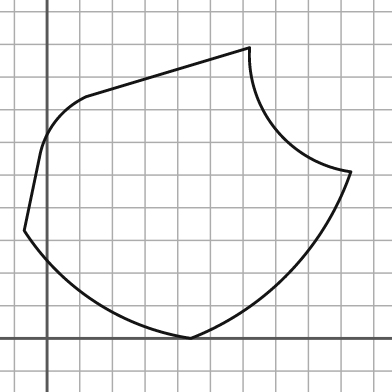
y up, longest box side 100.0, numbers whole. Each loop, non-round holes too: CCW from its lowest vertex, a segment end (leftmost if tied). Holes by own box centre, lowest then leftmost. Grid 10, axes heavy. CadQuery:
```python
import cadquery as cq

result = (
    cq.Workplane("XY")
    .moveTo(44.0, 0.0)
    .threePointArc((74.0, 20.0), (93.0, 51.0))
    .threePointArc((70.0, 64.0), (62.0, 89.0))
    .lineTo(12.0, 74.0)
    .threePointArc((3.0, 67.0), (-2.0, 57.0))
    .lineTo(-7.0, 33.0)
    .threePointArc((15.0, 11.0), (44.0, 0.0))
    .close()
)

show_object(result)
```